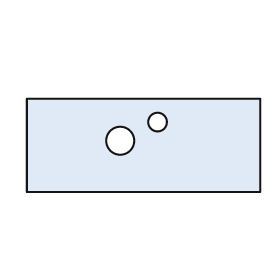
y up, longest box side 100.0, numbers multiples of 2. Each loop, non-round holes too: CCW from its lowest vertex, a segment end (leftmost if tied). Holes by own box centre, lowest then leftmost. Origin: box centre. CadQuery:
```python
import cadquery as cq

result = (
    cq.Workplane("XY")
    .moveTo(-50.0, -20.0)
    .lineTo(50.0, -20.0)
    .lineTo(50.0, 20.0)
    .lineTo(-50.0, 20.0)
    .close()
    .moveTo(-10.0, 2.0)
    .circle(6.0)
    .moveTo(6.0, 10.0)
    .circle(4.0)
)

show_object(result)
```